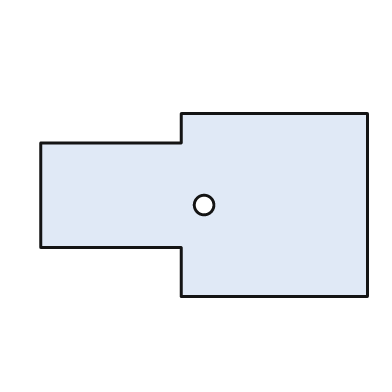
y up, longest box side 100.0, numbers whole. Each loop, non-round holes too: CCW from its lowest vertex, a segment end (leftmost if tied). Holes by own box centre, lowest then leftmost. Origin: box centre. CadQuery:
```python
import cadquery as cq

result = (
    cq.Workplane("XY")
    .moveTo(-7.0, -28.0)
    .lineTo(50.0, -28.0)
    .lineTo(50.0, 28.0)
    .lineTo(-7.0, 28.0)
    .lineTo(-7.0, 19.0)
    .lineTo(-50.0, 19.0)
    .lineTo(-50.0, -13.0)
    .lineTo(-7.0, -13.0)
    .close()
    .moveTo(0.0, 0.0)
    .circle(3.0)
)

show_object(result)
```